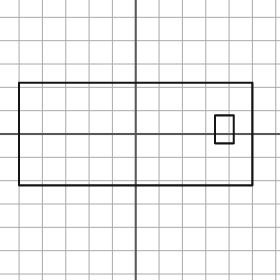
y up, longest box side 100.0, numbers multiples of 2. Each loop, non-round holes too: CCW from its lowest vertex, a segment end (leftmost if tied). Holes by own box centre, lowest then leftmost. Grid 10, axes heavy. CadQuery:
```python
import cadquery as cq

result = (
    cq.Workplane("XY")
    .moveTo(-50.0, -22.0)
    .lineTo(50.0, -22.0)
    .lineTo(50.0, 22.0)
    .lineTo(-50.0, 22.0)
    .close()
    .moveTo(34.0, -4.0)
    .lineTo(42.0, -4.0)
    .lineTo(42.0, 8.0)
    .lineTo(34.0, 8.0)
    .close()
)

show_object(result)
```